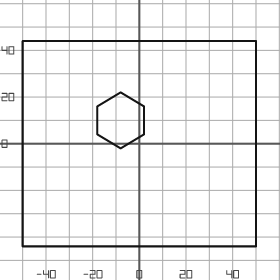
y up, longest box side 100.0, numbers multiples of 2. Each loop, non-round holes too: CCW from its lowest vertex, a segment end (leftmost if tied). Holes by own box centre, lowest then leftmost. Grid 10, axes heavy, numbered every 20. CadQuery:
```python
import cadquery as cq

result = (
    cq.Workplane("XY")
    .moveTo(-50.0, -44.0)
    .lineTo(50.0, -44.0)
    .lineTo(50.0, 44.0)
    .lineTo(-50.0, 44.0)
    .close()
    .moveTo(-8.0, -2.0)
    .lineTo(2.0, 4.0)
    .lineTo(2.0, 16.0)
    .lineTo(-8.0, 22.0)
    .lineTo(-18.0, 16.0)
    .lineTo(-18.0, 4.0)
    .close()
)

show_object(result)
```